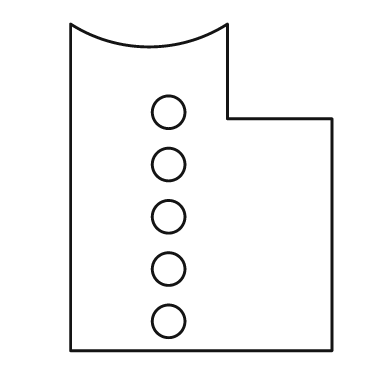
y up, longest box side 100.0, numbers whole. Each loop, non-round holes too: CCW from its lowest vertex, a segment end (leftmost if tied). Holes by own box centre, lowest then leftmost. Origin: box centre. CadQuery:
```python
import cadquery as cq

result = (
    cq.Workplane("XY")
    .moveTo(-40.0, -50.0)
    .lineTo(40.0, -50.0)
    .lineTo(40.0, 21.0)
    .lineTo(8.0, 21.0)
    .lineTo(8.0, 50.0)
    .threePointArc((-16.0, 43.0), (-40.0, 50.0))
    .close()
    .moveTo(-10.0, -41.0)
    .circle(5.0)
    .moveTo(-10.0, -25.0)
    .circle(5.0)
    .moveTo(-10.0, -9.0)
    .circle(5.0)
    .moveTo(-10.0, 7.0)
    .circle(5.0)
    .moveTo(-10.0, 23.0)
    .circle(5.0)
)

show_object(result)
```